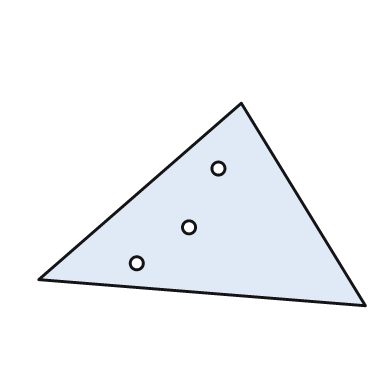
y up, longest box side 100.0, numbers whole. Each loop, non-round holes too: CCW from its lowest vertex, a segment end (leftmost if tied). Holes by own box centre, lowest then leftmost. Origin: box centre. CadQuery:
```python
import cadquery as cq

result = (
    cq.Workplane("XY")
    .moveTo(50.0, -31.0)
    .lineTo(12.0, 31.0)
    .lineTo(-50.0, -23.0)
    .close()
    .moveTo(-20.0, -18.0)
    .circle(2.0)
    .moveTo(-4.0, -7.0)
    .circle(2.0)
    .moveTo(5.0, 11.0)
    .circle(2.0)
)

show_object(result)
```